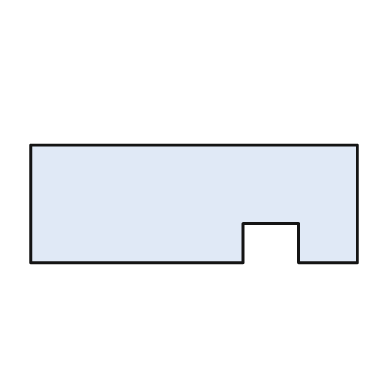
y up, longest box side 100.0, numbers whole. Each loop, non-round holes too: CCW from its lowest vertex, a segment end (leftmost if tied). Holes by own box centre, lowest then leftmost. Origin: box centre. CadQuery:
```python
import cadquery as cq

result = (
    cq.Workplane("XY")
    .moveTo(-50.0, -18.0)
    .lineTo(15.0, -18.0)
    .lineTo(15.0, -6.0)
    .lineTo(32.0, -6.0)
    .lineTo(32.0, -18.0)
    .lineTo(50.0, -18.0)
    .lineTo(50.0, 18.0)
    .lineTo(-50.0, 18.0)
    .close()
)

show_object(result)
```